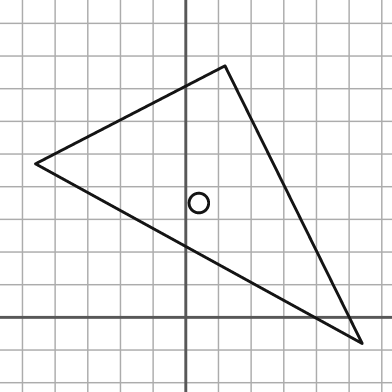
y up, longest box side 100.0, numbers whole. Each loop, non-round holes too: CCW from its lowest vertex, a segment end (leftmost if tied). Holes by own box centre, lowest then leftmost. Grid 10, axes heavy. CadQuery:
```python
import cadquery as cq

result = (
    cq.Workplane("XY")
    .moveTo(54.0, -8.0)
    .lineTo(12.0, 77.0)
    .lineTo(-46.0, 47.0)
    .close()
    .moveTo(4.0, 35.0)
    .circle(3.0)
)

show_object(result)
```